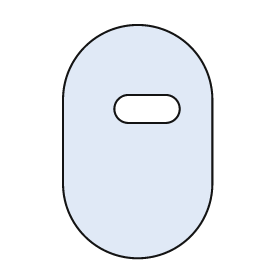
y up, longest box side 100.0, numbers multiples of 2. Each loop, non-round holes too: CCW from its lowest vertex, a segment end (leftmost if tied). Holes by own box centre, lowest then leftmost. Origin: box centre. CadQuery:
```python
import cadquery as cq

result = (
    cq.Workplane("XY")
    .moveTo(-32.0, -18.0)
    .threePointArc((0.0, -50.0), (32.0, -18.0))
    .lineTo(32.0, 18.0)
    .threePointArc((0.0, 50.0), (-32.0, 18.0))
    .close()
    .moveTo(-4.0, 8.0)
    .lineTo(12.0, 8.0)
    .threePointArc((18.0, 14.0), (12.0, 20.0))
    .lineTo(-4.0, 20.0)
    .threePointArc((-10.0, 14.0), (-4.0, 8.0))
    .close()
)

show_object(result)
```